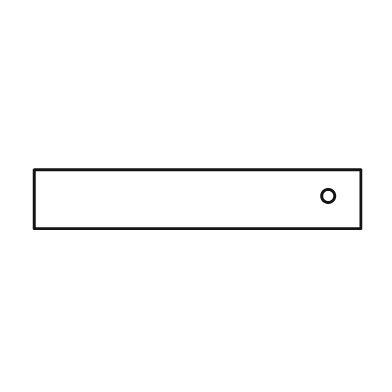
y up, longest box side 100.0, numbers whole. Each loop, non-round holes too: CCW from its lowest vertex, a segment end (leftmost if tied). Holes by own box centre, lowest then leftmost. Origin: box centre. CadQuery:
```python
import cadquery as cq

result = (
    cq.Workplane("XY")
    .moveTo(-50.0, -9.0)
    .lineTo(50.0, -9.0)
    .lineTo(50.0, 9.0)
    .lineTo(-50.0, 9.0)
    .close()
    .moveTo(40.0, 1.0)
    .circle(2.0)
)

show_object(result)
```